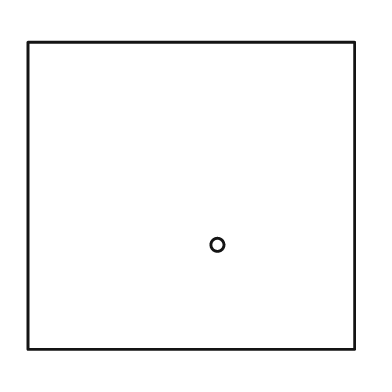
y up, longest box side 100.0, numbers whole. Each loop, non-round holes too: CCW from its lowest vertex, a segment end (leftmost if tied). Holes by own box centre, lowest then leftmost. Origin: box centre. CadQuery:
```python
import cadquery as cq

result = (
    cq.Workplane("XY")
    .moveTo(-50.0, -47.0)
    .lineTo(50.0, -47.0)
    .lineTo(50.0, 47.0)
    .lineTo(-50.0, 47.0)
    .close()
    .moveTo(8.0, -15.0)
    .circle(2.0)
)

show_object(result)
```